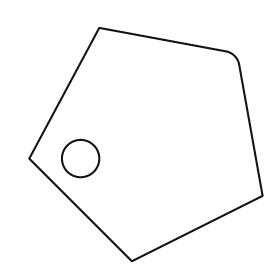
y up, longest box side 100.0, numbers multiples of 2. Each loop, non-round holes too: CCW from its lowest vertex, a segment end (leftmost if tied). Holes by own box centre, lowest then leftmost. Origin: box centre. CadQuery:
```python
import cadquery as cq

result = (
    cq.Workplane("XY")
    .moveTo(-6.0, -50.0)
    .lineTo(50.0, -22.0)
    .lineTo(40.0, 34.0)
    .threePointArc((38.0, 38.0), (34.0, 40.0))
    .lineTo(-20.0, 50.0)
    .lineTo(-50.0, -6.0)
    .close()
    .moveTo(-28.0, -6.0)
    .circle(8.0)
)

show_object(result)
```